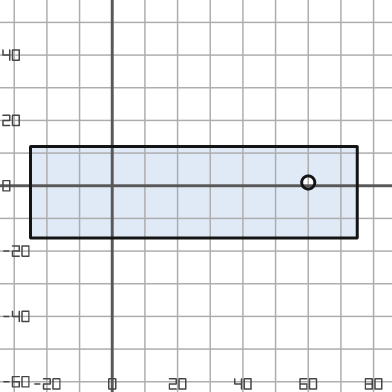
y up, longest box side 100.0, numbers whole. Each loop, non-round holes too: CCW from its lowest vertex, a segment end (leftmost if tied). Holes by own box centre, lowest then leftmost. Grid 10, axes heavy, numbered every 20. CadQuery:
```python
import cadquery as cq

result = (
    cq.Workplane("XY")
    .moveTo(-25.0, -16.0)
    .lineTo(75.0, -16.0)
    .lineTo(75.0, 12.0)
    .lineTo(-25.0, 12.0)
    .close()
    .moveTo(60.0, 1.0)
    .circle(2.0)
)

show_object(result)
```